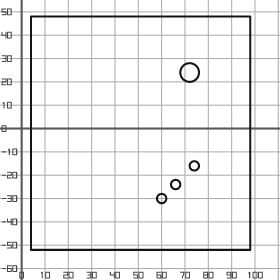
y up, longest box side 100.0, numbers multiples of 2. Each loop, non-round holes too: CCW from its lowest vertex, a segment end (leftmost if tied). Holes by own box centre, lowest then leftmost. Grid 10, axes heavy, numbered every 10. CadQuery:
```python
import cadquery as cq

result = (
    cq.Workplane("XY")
    .moveTo(4.0, -52.0)
    .lineTo(98.0, -52.0)
    .lineTo(98.0, 48.0)
    .lineTo(4.0, 48.0)
    .close()
    .moveTo(60.0, -30.0)
    .circle(2.0)
    .moveTo(66.0, -24.0)
    .circle(2.0)
    .moveTo(74.0, -16.0)
    .circle(2.0)
    .moveTo(72.0, 24.0)
    .circle(4.0)
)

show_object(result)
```